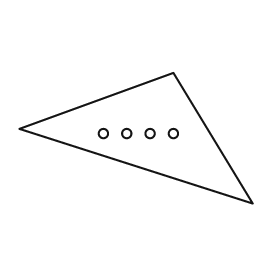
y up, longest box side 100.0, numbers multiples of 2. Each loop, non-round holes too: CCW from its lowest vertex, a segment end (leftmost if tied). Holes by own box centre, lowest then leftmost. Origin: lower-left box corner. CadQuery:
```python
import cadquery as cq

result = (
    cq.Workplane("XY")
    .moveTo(100.0, 0.0)
    .lineTo(66.0, 56.0)
    .lineTo(0.0, 32.0)
    .close()
    .moveTo(36.0, 30.0)
    .circle(2.0)
    .moveTo(46.0, 30.0)
    .circle(2.0)
    .moveTo(56.0, 30.0)
    .circle(2.0)
    .moveTo(66.0, 30.0)
    .circle(2.0)
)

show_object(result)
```